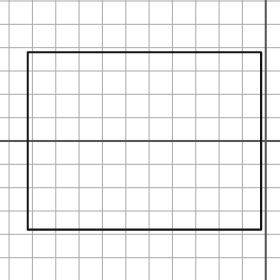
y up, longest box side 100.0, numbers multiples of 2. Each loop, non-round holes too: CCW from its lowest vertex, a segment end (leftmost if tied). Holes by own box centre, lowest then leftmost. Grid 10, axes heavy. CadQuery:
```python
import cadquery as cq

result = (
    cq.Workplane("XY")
    .moveTo(-102.0, -38.0)
    .lineTo(-2.0, -38.0)
    .lineTo(-2.0, 38.0)
    .lineTo(-102.0, 38.0)
    .close()
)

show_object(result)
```